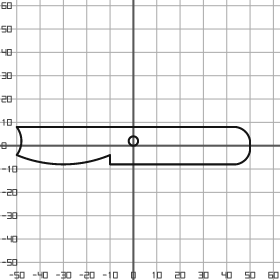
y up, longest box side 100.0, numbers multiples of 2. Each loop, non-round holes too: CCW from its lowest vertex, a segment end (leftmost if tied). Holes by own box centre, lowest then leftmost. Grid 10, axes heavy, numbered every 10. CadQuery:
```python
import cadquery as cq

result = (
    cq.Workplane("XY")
    .moveTo(-10.0, -8.0)
    .lineTo(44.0, -8.0)
    .threePointArc((48.0, -6.0), (50.0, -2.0))
    .lineTo(50.0, 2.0)
    .threePointArc((48.0, 6.0), (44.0, 8.0))
    .lineTo(-50.0, 8.0)
    .threePointArc((-48.0, 2.0), (-50.0, -4.0))
    .threePointArc((-30.0, -8.0), (-10.0, -4.0))
    .close()
    .moveTo(0.0, 2.0)
    .circle(2.0)
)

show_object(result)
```